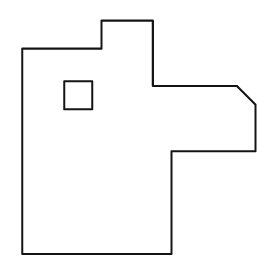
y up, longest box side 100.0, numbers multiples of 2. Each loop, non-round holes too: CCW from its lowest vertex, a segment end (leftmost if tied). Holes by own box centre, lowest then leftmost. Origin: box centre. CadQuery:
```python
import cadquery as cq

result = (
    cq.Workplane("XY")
    .moveTo(-50.0, -50.0)
    .lineTo(14.0, -50.0)
    .lineTo(14.0, -6.0)
    .lineTo(50.0, -6.0)
    .lineTo(50.0, 14.0)
    .lineTo(42.0, 22.0)
    .lineTo(6.0, 22.0)
    .lineTo(6.0, 50.0)
    .lineTo(-16.0, 50.0)
    .lineTo(-16.0, 38.0)
    .lineTo(-50.0, 38.0)
    .close()
    .moveTo(-32.0, 12.0)
    .lineTo(-20.0, 12.0)
    .lineTo(-20.0, 24.0)
    .lineTo(-32.0, 24.0)
    .close()
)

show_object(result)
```